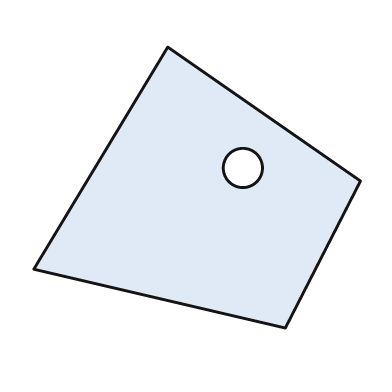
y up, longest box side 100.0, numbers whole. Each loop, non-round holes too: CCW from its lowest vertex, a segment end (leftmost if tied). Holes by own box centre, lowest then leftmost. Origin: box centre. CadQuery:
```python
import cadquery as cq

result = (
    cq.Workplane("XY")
    .moveTo(27.0, -43.0)
    .lineTo(50.0, 2.0)
    .lineTo(-9.0, 43.0)
    .lineTo(-50.0, -25.0)
    .close()
    .moveTo(14.0, 6.0)
    .circle(6.0)
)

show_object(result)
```